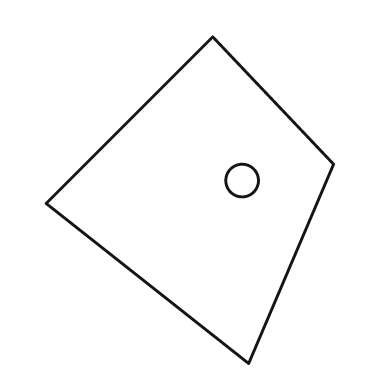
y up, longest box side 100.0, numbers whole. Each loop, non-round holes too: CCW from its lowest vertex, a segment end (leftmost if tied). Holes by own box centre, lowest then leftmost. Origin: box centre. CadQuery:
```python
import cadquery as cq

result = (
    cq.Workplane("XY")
    .moveTo(18.0, -50.0)
    .lineTo(44.0, 11.0)
    .lineTo(7.0, 50.0)
    .lineTo(-44.0, -1.0)
    .close()
    .moveTo(16.0, 6.0)
    .circle(5.0)
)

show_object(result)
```